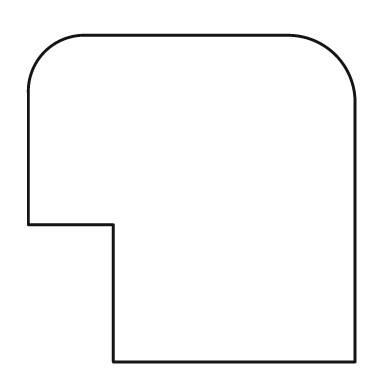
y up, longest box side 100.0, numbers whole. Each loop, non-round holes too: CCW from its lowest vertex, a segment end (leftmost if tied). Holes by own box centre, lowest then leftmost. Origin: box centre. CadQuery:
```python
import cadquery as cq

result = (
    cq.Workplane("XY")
    .moveTo(-24.0, -50.0)
    .lineTo(50.0, -50.0)
    .lineTo(50.0, 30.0)
    .threePointArc((44.0, 44.0), (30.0, 50.0))
    .lineTo(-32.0, 50.0)
    .threePointArc((-45.0, 45.0), (-50.0, 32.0))
    .lineTo(-50.0, -8.0)
    .lineTo(-24.0, -8.0)
    .close()
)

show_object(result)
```